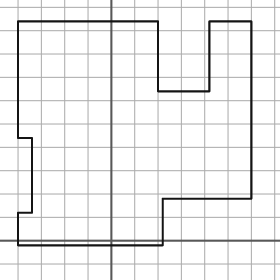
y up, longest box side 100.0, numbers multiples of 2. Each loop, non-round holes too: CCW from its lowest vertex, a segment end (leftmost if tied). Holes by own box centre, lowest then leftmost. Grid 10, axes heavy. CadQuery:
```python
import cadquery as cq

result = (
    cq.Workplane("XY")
    .moveTo(-40.0, -2.0)
    .lineTo(22.0, -2.0)
    .lineTo(22.0, 18.0)
    .lineTo(60.0, 18.0)
    .lineTo(60.0, 94.0)
    .lineTo(42.0, 94.0)
    .lineTo(42.0, 64.0)
    .lineTo(20.0, 64.0)
    .lineTo(20.0, 94.0)
    .lineTo(-40.0, 94.0)
    .lineTo(-40.0, 44.0)
    .lineTo(-34.0, 44.0)
    .lineTo(-34.0, 12.0)
    .lineTo(-40.0, 12.0)
    .close()
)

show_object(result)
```